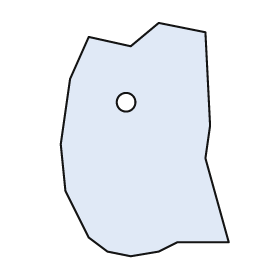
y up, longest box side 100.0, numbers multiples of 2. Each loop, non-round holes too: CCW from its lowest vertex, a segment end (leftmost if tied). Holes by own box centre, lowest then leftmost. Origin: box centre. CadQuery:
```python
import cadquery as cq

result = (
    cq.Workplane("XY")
    .moveTo(-6.0, -50.0)
    .lineTo(6.0, -48.0)
    .lineTo(14.0, -44.0)
    .lineTo(36.0, -44.0)
    .lineTo(26.0, -8.0)
    .lineTo(28.0, 6.0)
    .lineTo(26.0, 46.0)
    .lineTo(6.0, 50.0)
    .lineTo(-6.0, 40.0)
    .lineTo(-24.0, 44.0)
    .lineTo(-32.0, 26.0)
    .lineTo(-36.0, -2.0)
    .lineTo(-34.0, -22.0)
    .lineTo(-24.0, -42.0)
    .lineTo(-16.0, -48.0)
    .close()
    .moveTo(-8.0, 16.0)
    .circle(4.0)
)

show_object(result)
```